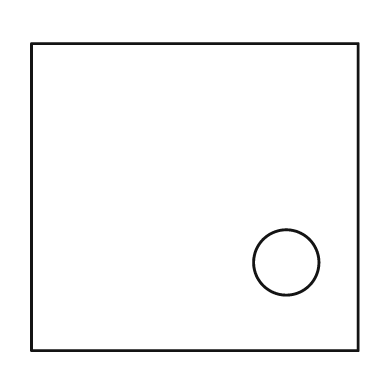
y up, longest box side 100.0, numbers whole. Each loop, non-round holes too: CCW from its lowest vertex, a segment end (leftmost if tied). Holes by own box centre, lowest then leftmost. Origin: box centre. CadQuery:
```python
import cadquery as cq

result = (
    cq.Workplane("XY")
    .moveTo(-50.0, -47.0)
    .lineTo(50.0, -47.0)
    .lineTo(50.0, 47.0)
    .lineTo(-50.0, 47.0)
    .close()
    .moveTo(28.0, -20.0)
    .circle(10.0)
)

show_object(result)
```